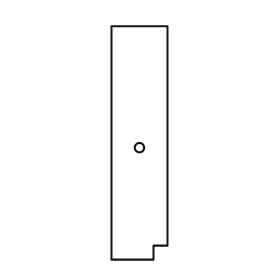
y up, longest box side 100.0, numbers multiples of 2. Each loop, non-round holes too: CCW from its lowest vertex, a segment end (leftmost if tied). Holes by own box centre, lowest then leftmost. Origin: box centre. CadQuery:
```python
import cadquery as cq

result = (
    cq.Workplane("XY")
    .moveTo(-12.0, -50.0)
    .lineTo(6.0, -50.0)
    .lineTo(6.0, -44.0)
    .lineTo(12.0, -44.0)
    .lineTo(12.0, 50.0)
    .lineTo(-12.0, 50.0)
    .close()
    .moveTo(0.0, -2.0)
    .circle(2.0)
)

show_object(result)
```